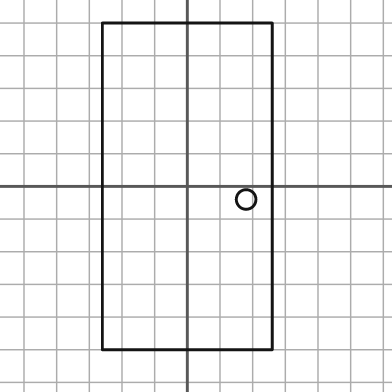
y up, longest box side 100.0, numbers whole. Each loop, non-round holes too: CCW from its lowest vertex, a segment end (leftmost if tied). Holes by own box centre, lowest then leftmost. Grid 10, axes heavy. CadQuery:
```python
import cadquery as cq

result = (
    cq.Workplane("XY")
    .moveTo(-26.0, -50.0)
    .lineTo(26.0, -50.0)
    .lineTo(26.0, 50.0)
    .lineTo(-26.0, 50.0)
    .close()
    .moveTo(18.0, -4.0)
    .circle(3.0)
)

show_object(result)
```